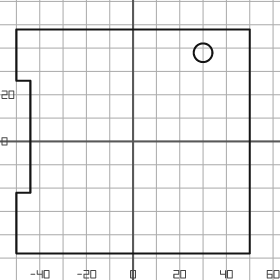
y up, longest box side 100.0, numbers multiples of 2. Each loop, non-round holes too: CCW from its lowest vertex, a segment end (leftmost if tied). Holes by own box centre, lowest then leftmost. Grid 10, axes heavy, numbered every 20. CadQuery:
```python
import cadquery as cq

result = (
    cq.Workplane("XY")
    .moveTo(-50.0, -48.0)
    .lineTo(50.0, -48.0)
    .lineTo(50.0, 48.0)
    .lineTo(-50.0, 48.0)
    .lineTo(-50.0, 26.0)
    .lineTo(-44.0, 26.0)
    .lineTo(-44.0, -22.0)
    .lineTo(-50.0, -22.0)
    .close()
    .moveTo(30.0, 38.0)
    .circle(4.0)
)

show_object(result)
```